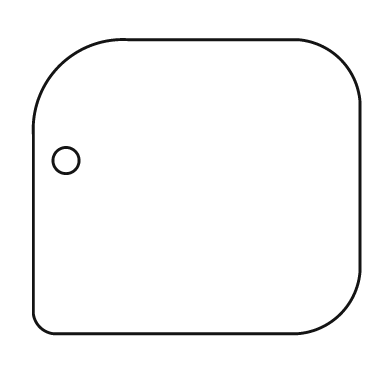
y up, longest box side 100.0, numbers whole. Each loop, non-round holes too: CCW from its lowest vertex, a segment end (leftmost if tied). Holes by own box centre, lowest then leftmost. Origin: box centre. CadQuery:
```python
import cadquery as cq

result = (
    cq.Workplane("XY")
    .moveTo(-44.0, -45.0)
    .lineTo(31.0, -45.0)
    .threePointArc((44.0, -39.0), (50.0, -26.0))
    .lineTo(50.0, 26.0)
    .threePointArc((44.0, 39.0), (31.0, 45.0))
    .lineTo(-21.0, 45.0)
    .threePointArc((-42.0, 37.0), (-50.0, 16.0))
    .lineTo(-50.0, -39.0)
    .threePointArc((-48.0, -43.0), (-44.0, -45.0))
    .close()
    .moveTo(-40.0, 8.0)
    .circle(4.0)
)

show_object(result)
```